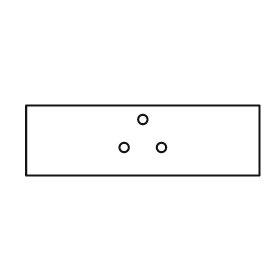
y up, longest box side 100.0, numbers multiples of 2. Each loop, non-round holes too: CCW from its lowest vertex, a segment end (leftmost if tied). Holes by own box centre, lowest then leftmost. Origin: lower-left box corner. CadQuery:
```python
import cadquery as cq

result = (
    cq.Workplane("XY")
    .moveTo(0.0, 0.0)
    .lineTo(100.0, 0.0)
    .lineTo(100.0, 30.0)
    .lineTo(0.0, 30.0)
    .close()
    .moveTo(42.0, 12.0)
    .circle(2.0)
    .moveTo(58.0, 12.0)
    .circle(2.0)
    .moveTo(50.0, 24.0)
    .circle(2.0)
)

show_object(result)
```